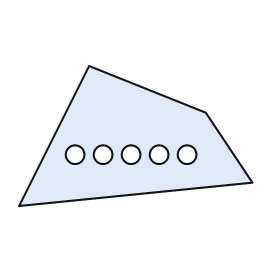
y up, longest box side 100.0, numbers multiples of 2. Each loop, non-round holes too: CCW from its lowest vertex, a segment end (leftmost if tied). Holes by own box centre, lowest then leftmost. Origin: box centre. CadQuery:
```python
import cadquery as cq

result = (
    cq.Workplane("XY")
    .moveTo(-50.0, -30.0)
    .lineTo(50.0, -20.0)
    .lineTo(30.0, 10.0)
    .lineTo(-20.0, 30.0)
    .close()
    .moveTo(-26.0, -8.0)
    .circle(4.0)
    .moveTo(-14.0, -8.0)
    .circle(4.0)
    .moveTo(-2.0, -8.0)
    .circle(4.0)
    .moveTo(10.0, -8.0)
    .circle(4.0)
    .moveTo(22.0, -8.0)
    .circle(4.0)
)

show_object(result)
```